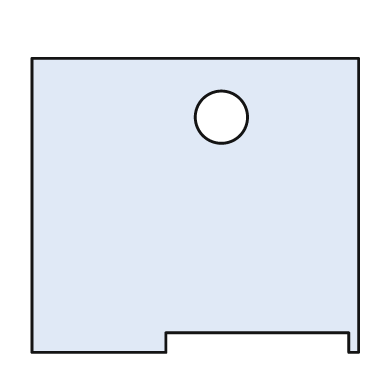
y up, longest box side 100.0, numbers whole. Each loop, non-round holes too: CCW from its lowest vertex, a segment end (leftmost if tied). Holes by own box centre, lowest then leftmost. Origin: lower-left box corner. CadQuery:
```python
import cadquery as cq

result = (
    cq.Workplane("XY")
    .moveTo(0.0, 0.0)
    .lineTo(41.0, 0.0)
    .lineTo(41.0, 6.0)
    .lineTo(97.0, 6.0)
    .lineTo(97.0, 0.0)
    .lineTo(100.0, 0.0)
    .lineTo(100.0, 90.0)
    .lineTo(0.0, 90.0)
    .close()
    .moveTo(58.0, 72.0)
    .circle(8.0)
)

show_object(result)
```